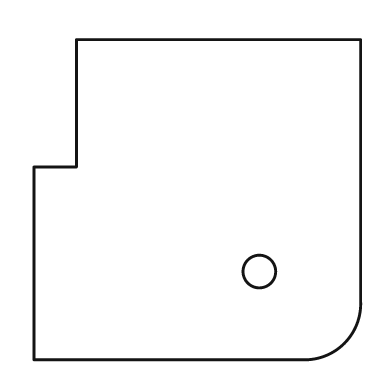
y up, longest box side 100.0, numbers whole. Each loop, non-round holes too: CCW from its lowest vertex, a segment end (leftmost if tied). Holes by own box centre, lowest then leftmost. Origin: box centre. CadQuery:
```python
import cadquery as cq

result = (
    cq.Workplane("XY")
    .moveTo(-50.0, -49.0)
    .lineTo(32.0, -49.0)
    .threePointArc((45.0, -44.0), (50.0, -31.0))
    .lineTo(50.0, 49.0)
    .lineTo(-37.0, 49.0)
    .lineTo(-37.0, 10.0)
    .lineTo(-50.0, 10.0)
    .close()
    .moveTo(19.0, -22.0)
    .circle(5.0)
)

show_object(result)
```